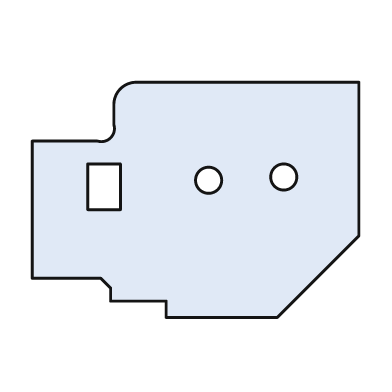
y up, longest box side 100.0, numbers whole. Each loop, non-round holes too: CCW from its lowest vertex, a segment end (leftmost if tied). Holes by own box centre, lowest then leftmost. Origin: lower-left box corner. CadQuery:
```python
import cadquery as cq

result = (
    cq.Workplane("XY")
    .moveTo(41.0, 0.0)
    .lineTo(75.0, 0.0)
    .lineTo(100.0, 25.0)
    .lineTo(100.0, 72.0)
    .lineTo(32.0, 72.0)
    .threePointArc((27.0, 70.0), (25.0, 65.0))
    .lineTo(25.0, 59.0)
    .threePointArc((24.0, 55.0), (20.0, 54.0))
    .lineTo(0.0, 54.0)
    .lineTo(0.0, 12.0)
    .lineTo(21.0, 12.0)
    .lineTo(24.0, 9.0)
    .lineTo(24.0, 5.0)
    .lineTo(41.0, 5.0)
    .close()
    .moveTo(17.0, 33.0)
    .lineTo(27.0, 33.0)
    .lineTo(27.0, 47.0)
    .lineTo(17.0, 47.0)
    .close()
    .moveTo(54.0, 42.0)
    .circle(4.0)
    .moveTo(77.0, 43.0)
    .circle(4.0)
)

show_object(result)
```